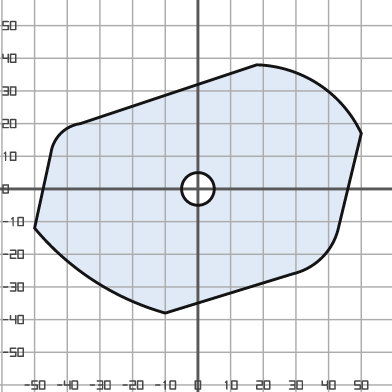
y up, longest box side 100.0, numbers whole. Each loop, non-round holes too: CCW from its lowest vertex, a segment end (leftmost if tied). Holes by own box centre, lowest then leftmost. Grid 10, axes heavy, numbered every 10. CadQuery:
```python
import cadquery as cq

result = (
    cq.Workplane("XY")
    .moveTo(-10.0, -38.0)
    .lineTo(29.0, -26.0)
    .threePointArc((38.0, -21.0), (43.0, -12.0))
    .lineTo(50.0, 17.0)
    .threePointArc((37.0, 32.0), (18.0, 38.0))
    .lineTo(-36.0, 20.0)
    .threePointArc((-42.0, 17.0), (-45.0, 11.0))
    .lineTo(-50.0, -12.0)
    .threePointArc((-32.0, -28.0), (-10.0, -38.0))
    .close()
    .moveTo(0.0, 0.0)
    .circle(5.0)
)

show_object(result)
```